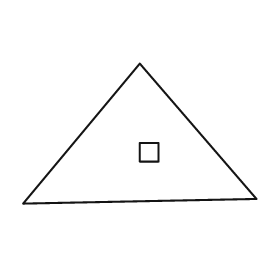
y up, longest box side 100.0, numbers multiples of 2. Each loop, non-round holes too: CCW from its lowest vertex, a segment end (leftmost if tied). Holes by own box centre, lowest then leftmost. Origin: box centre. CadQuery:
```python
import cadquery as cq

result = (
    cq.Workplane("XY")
    .moveTo(-50.0, -30.0)
    .lineTo(50.0, -28.0)
    .lineTo(0.0, 30.0)
    .close()
    .moveTo(0.0, -12.0)
    .lineTo(8.0, -12.0)
    .lineTo(8.0, -4.0)
    .lineTo(0.0, -4.0)
    .close()
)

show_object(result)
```